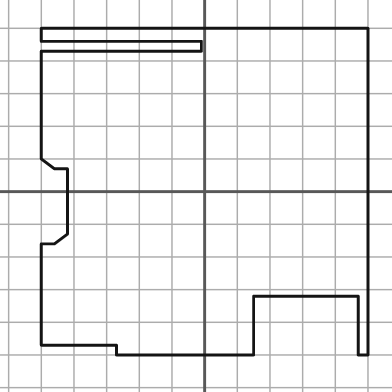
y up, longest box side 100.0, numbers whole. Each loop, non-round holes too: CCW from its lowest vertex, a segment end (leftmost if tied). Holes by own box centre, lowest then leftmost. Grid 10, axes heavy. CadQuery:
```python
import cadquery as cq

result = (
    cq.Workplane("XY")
    .moveTo(-27.0, -50.0)
    .lineTo(15.0, -50.0)
    .lineTo(15.0, -32.0)
    .lineTo(47.0, -32.0)
    .lineTo(47.0, -50.0)
    .lineTo(50.0, -50.0)
    .lineTo(50.0, 50.0)
    .lineTo(-50.0, 50.0)
    .lineTo(-50.0, 46.0)
    .lineTo(-1.0, 46.0)
    .lineTo(-1.0, 43.0)
    .lineTo(-50.0, 43.0)
    .lineTo(-50.0, 10.0)
    .lineTo(-46.0, 7.0)
    .lineTo(-42.0, 7.0)
    .lineTo(-42.0, -13.0)
    .lineTo(-46.0, -16.0)
    .lineTo(-50.0, -16.0)
    .lineTo(-50.0, -47.0)
    .lineTo(-27.0, -47.0)
    .close()
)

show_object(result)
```